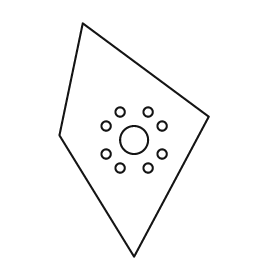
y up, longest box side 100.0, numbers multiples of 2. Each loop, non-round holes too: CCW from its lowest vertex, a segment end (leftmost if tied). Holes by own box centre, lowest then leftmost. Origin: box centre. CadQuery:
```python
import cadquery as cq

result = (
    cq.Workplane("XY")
    .moveTo(0.0, -50.0)
    .lineTo(32.0, 10.0)
    .lineTo(-22.0, 50.0)
    .lineTo(-32.0, 2.0)
    .close()
    .moveTo(-6.0, -12.0)
    .circle(2.0)
    .moveTo(6.0, -12.0)
    .circle(2.0)
    .moveTo(-12.0, -6.0)
    .circle(2.0)
    .moveTo(12.0, -6.0)
    .circle(2.0)
    .moveTo(0.0, 0.0)
    .circle(6.0)
    .moveTo(-12.0, 6.0)
    .circle(2.0)
    .moveTo(12.0, 6.0)
    .circle(2.0)
    .moveTo(-6.0, 12.0)
    .circle(2.0)
    .moveTo(6.0, 12.0)
    .circle(2.0)
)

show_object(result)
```